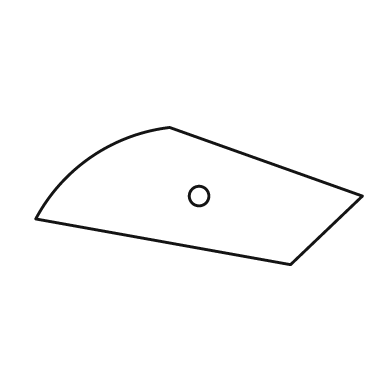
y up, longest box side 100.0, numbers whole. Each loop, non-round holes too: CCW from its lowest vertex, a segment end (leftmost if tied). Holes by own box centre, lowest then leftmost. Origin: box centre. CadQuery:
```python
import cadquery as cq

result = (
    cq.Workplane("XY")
    .moveTo(28.0, -21.0)
    .lineTo(50.0, 0.0)
    .lineTo(-9.0, 21.0)
    .threePointArc((-33.0, 12.0), (-50.0, -7.0))
    .close()
    .moveTo(0.0, 0.0)
    .circle(3.0)
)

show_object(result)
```